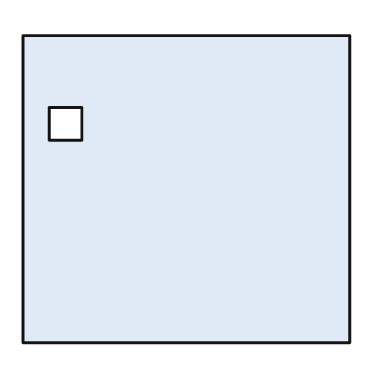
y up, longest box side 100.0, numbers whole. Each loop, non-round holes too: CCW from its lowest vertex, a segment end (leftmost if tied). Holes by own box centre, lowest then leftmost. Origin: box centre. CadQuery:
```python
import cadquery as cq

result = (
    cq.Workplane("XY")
    .moveTo(-50.0, -47.0)
    .lineTo(50.0, -47.0)
    .lineTo(50.0, 47.0)
    .lineTo(-50.0, 47.0)
    .close()
    .moveTo(-42.0, 15.0)
    .lineTo(-32.0, 15.0)
    .lineTo(-32.0, 25.0)
    .lineTo(-42.0, 25.0)
    .close()
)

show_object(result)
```